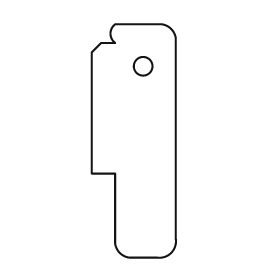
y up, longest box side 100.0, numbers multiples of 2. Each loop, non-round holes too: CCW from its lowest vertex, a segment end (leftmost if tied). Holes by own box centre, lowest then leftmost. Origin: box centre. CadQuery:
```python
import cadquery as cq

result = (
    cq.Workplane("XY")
    .moveTo(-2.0, -50.0)
    .lineTo(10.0, -50.0)
    .threePointArc((16.0, -48.0), (18.0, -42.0))
    .lineTo(18.0, 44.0)
    .threePointArc((16.0, 48.0), (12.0, 50.0))
    .lineTo(-8.0, 50.0)
    .threePointArc((-10.0, 46.0), (-8.0, 42.0))
    .lineTo(-14.0, 42.0)
    .lineTo(-18.0, 38.0)
    .lineTo(-18.0, -14.0)
    .lineTo(-8.0, -14.0)
    .lineTo(-8.0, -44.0)
    .threePointArc((-6.0, -48.0), (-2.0, -50.0))
    .close()
    .moveTo(4.0, 32.0)
    .circle(4.0)
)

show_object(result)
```